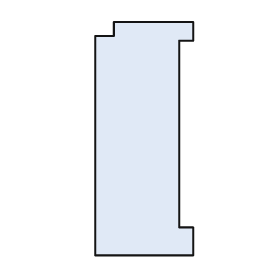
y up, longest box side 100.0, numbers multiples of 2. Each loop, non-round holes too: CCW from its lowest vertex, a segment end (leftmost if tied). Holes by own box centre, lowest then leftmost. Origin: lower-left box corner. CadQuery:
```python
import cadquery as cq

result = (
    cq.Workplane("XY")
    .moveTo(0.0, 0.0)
    .lineTo(42.0, 0.0)
    .lineTo(42.0, 12.0)
    .lineTo(36.0, 12.0)
    .lineTo(36.0, 92.0)
    .lineTo(42.0, 92.0)
    .lineTo(42.0, 100.0)
    .lineTo(8.0, 100.0)
    .lineTo(8.0, 94.0)
    .lineTo(0.0, 94.0)
    .close()
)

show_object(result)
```